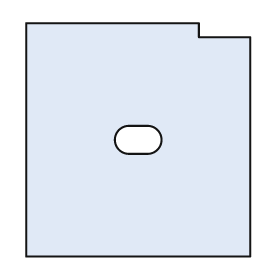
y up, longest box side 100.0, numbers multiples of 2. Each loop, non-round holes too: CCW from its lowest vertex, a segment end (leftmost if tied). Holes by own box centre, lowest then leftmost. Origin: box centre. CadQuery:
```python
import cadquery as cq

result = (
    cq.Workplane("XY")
    .moveTo(-48.0, -50.0)
    .lineTo(48.0, -50.0)
    .lineTo(48.0, 44.0)
    .lineTo(26.0, 44.0)
    .lineTo(26.0, 50.0)
    .lineTo(-48.0, 50.0)
    .close()
    .moveTo(-4.0, -6.0)
    .lineTo(4.0, -6.0)
    .threePointArc((10.0, 0.0), (4.0, 6.0))
    .lineTo(-4.0, 6.0)
    .threePointArc((-10.0, 0.0), (-4.0, -6.0))
    .close()
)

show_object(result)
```